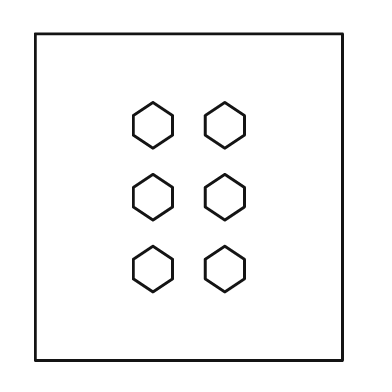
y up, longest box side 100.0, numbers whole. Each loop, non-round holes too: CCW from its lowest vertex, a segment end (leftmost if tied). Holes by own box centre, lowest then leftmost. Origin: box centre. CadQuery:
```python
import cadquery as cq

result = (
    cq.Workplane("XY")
    .moveTo(-47.0, -50.0)
    .lineTo(47.0, -50.0)
    .lineTo(47.0, 50.0)
    .lineTo(-47.0, 50.0)
    .close()
    .moveTo(-11.0, -29.0)
    .lineTo(-5.0, -25.0)
    .lineTo(-5.0, -19.0)
    .lineTo(-11.0, -15.0)
    .lineTo(-17.0, -19.0)
    .lineTo(-17.0, -25.0)
    .close()
    .moveTo(11.0, -29.0)
    .lineTo(17.0, -25.0)
    .lineTo(17.0, -19.0)
    .lineTo(11.0, -15.0)
    .lineTo(5.0, -19.0)
    .lineTo(5.0, -25.0)
    .close()
    .moveTo(-11.0, -7.0)
    .lineTo(-5.0, -3.0)
    .lineTo(-5.0, 3.0)
    .lineTo(-11.0, 7.0)
    .lineTo(-17.0, 3.0)
    .lineTo(-17.0, -3.0)
    .close()
    .moveTo(11.0, -7.0)
    .lineTo(17.0, -3.0)
    .lineTo(17.0, 3.0)
    .lineTo(11.0, 7.0)
    .lineTo(5.0, 3.0)
    .lineTo(5.0, -3.0)
    .close()
    .moveTo(-11.0, 15.0)
    .lineTo(-5.0, 19.0)
    .lineTo(-5.0, 25.0)
    .lineTo(-11.0, 29.0)
    .lineTo(-17.0, 25.0)
    .lineTo(-17.0, 19.0)
    .close()
    .moveTo(11.0, 15.0)
    .lineTo(17.0, 19.0)
    .lineTo(17.0, 25.0)
    .lineTo(11.0, 29.0)
    .lineTo(5.0, 25.0)
    .lineTo(5.0, 19.0)
    .close()
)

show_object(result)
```